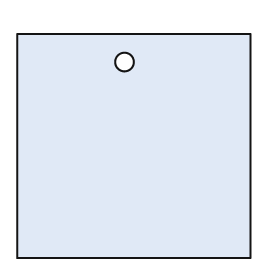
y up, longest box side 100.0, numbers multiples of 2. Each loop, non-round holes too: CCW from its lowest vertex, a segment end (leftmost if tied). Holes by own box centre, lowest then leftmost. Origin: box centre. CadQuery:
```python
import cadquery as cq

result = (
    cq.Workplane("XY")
    .moveTo(-50.0, -48.0)
    .lineTo(50.0, -48.0)
    .lineTo(50.0, 48.0)
    .lineTo(-50.0, 48.0)
    .close()
    .moveTo(-4.0, 36.0)
    .circle(4.0)
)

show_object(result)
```